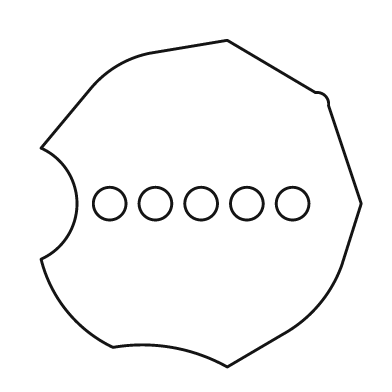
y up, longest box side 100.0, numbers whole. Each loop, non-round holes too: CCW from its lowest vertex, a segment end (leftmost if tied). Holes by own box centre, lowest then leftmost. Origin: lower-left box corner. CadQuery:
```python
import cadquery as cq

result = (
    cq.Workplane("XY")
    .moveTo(57.0, 0.0)
    .lineTo(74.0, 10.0)
    .threePointArc((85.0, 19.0), (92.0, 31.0))
    .lineTo(98.0, 50.0)
    .lineTo(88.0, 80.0)
    .threePointArc((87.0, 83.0), (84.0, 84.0))
    .lineTo(57.0, 100.0)
    .lineTo(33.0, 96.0)
    .threePointArc((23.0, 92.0), (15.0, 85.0))
    .lineTo(0.0, 67.0)
    .threePointArc((11.0, 50.0), (0.0, 33.0))
    .threePointArc((8.0, 17.0), (22.0, 6.0))
    .threePointArc((40.0, 6.0), (57.0, 0.0))
    .close()
    .moveTo(21.0, 50.0)
    .circle(5.0)
    .moveTo(35.0, 50.0)
    .circle(5.0)
    .moveTo(49.0, 50.0)
    .circle(5.0)
    .moveTo(63.0, 50.0)
    .circle(5.0)
    .moveTo(77.0, 50.0)
    .circle(5.0)
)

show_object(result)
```